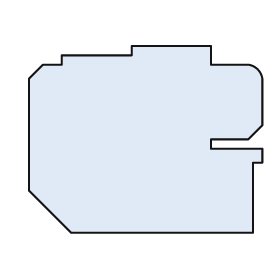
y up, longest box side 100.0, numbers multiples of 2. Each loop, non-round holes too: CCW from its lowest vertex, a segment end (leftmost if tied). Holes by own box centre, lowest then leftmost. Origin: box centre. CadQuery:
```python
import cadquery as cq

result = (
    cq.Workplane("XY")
    .moveTo(-32.0, -40.0)
    .lineTo(46.0, -40.0)
    .lineTo(46.0, -10.0)
    .lineTo(50.0, -10.0)
    .lineTo(50.0, -4.0)
    .lineTo(28.0, -4.0)
    .lineTo(28.0, 0.0)
    .lineTo(44.0, 0.0)
    .lineTo(50.0, 6.0)
    .lineTo(50.0, 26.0)
    .threePointArc((48.0, 30.0), (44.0, 32.0))
    .lineTo(28.0, 32.0)
    .lineTo(28.0, 40.0)
    .lineTo(-6.0, 40.0)
    .lineTo(-6.0, 36.0)
    .lineTo(-36.0, 36.0)
    .lineTo(-36.0, 32.0)
    .lineTo(-44.0, 32.0)
    .lineTo(-50.0, 26.0)
    .lineTo(-50.0, -22.0)
    .close()
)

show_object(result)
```